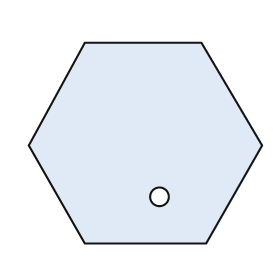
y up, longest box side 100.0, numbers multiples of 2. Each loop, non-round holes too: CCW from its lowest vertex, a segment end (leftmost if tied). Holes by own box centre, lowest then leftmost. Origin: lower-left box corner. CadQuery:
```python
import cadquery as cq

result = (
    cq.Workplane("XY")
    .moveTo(24.0, 0.0)
    .lineTo(76.0, 0.0)
    .lineTo(100.0, 42.0)
    .lineTo(74.0, 86.0)
    .lineTo(24.0, 86.0)
    .lineTo(0.0, 42.0)
    .close()
    .moveTo(56.0, 20.0)
    .circle(4.0)
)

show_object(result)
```